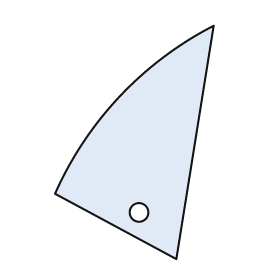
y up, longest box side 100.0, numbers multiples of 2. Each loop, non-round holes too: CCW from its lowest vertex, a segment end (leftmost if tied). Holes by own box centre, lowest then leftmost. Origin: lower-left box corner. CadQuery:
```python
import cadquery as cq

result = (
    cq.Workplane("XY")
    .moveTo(52.0, 0.0)
    .lineTo(68.0, 100.0)
    .threePointArc((28.0, 70.0), (0.0, 28.0))
    .close()
    .moveTo(36.0, 20.0)
    .circle(4.0)
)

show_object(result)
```